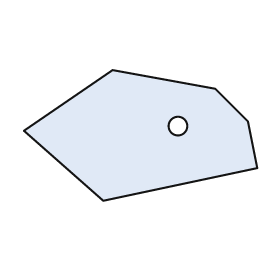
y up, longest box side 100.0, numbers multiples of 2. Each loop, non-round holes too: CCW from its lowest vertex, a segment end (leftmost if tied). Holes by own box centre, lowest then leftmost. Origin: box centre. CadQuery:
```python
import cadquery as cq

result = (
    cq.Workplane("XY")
    .moveTo(-16.0, -28.0)
    .lineTo(50.0, -14.0)
    .lineTo(46.0, 6.0)
    .lineTo(32.0, 20.0)
    .lineTo(-12.0, 28.0)
    .lineTo(-50.0, 2.0)
    .close()
    .moveTo(16.0, 4.0)
    .circle(4.0)
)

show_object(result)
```